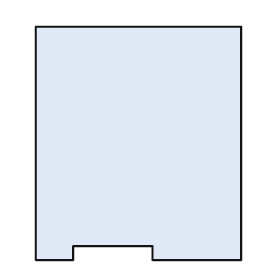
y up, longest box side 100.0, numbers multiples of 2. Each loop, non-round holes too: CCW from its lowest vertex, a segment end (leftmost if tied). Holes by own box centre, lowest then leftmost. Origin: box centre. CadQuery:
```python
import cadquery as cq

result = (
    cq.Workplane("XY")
    .moveTo(-44.0, -50.0)
    .lineTo(-28.0, -50.0)
    .lineTo(-28.0, -44.0)
    .lineTo(6.0, -44.0)
    .lineTo(6.0, -50.0)
    .lineTo(44.0, -50.0)
    .lineTo(44.0, 50.0)
    .lineTo(-44.0, 50.0)
    .close()
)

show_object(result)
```